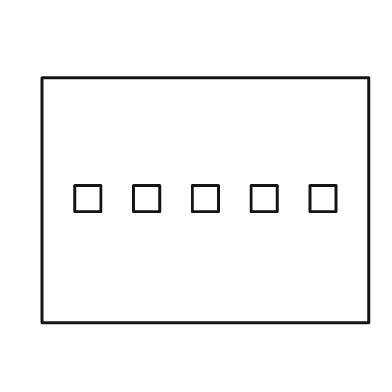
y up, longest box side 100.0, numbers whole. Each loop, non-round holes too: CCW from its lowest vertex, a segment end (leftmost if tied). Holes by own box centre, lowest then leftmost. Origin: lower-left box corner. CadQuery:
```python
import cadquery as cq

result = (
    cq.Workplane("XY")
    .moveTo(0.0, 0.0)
    .lineTo(100.0, 0.0)
    .lineTo(100.0, 75.0)
    .lineTo(0.0, 75.0)
    .close()
    .moveTo(10.0, 34.0)
    .lineTo(18.0, 34.0)
    .lineTo(18.0, 42.0)
    .lineTo(10.0, 42.0)
    .close()
    .moveTo(28.0, 34.0)
    .lineTo(36.0, 34.0)
    .lineTo(36.0, 42.0)
    .lineTo(28.0, 42.0)
    .close()
    .moveTo(46.0, 34.0)
    .lineTo(54.0, 34.0)
    .lineTo(54.0, 42.0)
    .lineTo(46.0, 42.0)
    .close()
    .moveTo(64.0, 34.0)
    .lineTo(72.0, 34.0)
    .lineTo(72.0, 42.0)
    .lineTo(64.0, 42.0)
    .close()
    .moveTo(82.0, 34.0)
    .lineTo(90.0, 34.0)
    .lineTo(90.0, 42.0)
    .lineTo(82.0, 42.0)
    .close()
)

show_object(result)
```